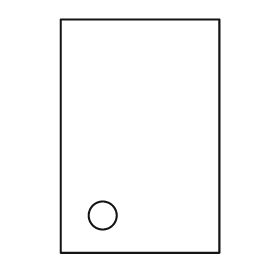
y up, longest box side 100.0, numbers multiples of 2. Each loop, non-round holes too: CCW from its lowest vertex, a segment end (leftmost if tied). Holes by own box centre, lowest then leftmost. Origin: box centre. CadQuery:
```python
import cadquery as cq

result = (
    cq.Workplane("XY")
    .moveTo(-34.0, -50.0)
    .lineTo(34.0, -50.0)
    .lineTo(34.0, 50.0)
    .lineTo(-34.0, 50.0)
    .close()
    .moveTo(-16.0, -34.0)
    .circle(6.0)
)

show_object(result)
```